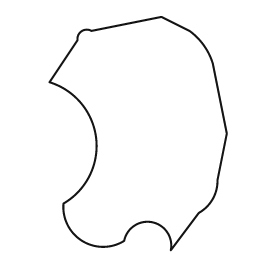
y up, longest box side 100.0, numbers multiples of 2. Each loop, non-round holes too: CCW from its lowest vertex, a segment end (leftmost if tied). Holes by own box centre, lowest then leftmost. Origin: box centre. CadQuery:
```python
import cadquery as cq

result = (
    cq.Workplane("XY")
    .moveTo(14.0, -50.0)
    .lineTo(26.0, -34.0)
    .threePointArc((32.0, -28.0), (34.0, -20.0))
    .lineTo(38.0, 0.0)
    .lineTo(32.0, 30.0)
    .threePointArc((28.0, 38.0), (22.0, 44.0))
    .lineTo(10.0, 50.0)
    .lineTo(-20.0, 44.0)
    .threePointArc((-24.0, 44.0), (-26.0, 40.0))
    .lineTo(-38.0, 22.0)
    .threePointArc((-18.0, -2.0), (-32.0, -30.0))
    .threePointArc((-24.0, -46.0), (-6.0, -46.0))
    .threePointArc((6.0, -38.0), (14.0, -50.0))
    .close()
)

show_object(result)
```